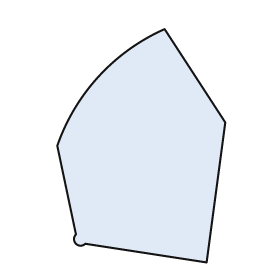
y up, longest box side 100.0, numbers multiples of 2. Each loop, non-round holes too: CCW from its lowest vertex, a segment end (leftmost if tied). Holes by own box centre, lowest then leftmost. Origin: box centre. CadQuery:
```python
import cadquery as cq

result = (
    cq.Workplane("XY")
    .moveTo(28.0, -50.0)
    .lineTo(36.0, 10.0)
    .lineTo(10.0, 50.0)
    .threePointArc((-18.0, 30.0), (-36.0, 0.0))
    .lineTo(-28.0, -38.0)
    .threePointArc((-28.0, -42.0), (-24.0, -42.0))
    .close()
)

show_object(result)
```